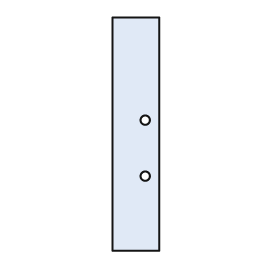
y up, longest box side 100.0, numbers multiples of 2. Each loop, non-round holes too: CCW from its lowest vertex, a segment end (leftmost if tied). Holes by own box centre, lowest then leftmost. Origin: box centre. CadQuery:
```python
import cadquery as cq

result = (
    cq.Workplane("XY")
    .moveTo(-10.0, -50.0)
    .lineTo(10.0, -50.0)
    .lineTo(10.0, 50.0)
    .lineTo(-10.0, 50.0)
    .close()
    .moveTo(4.0, -18.0)
    .circle(2.0)
    .moveTo(4.0, 6.0)
    .circle(2.0)
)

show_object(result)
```